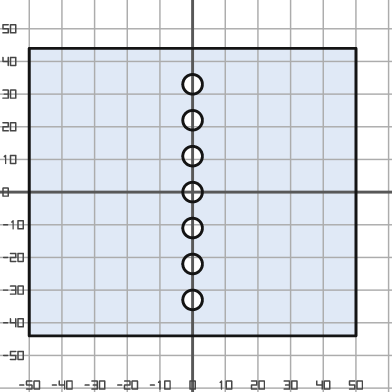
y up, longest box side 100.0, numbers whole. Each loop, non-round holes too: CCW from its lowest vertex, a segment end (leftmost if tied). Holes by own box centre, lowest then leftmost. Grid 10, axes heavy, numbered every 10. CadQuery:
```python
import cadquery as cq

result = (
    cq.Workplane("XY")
    .moveTo(-50.0, -44.0)
    .lineTo(50.0, -44.0)
    .lineTo(50.0, 44.0)
    .lineTo(-50.0, 44.0)
    .close()
    .moveTo(0.0, -33.0)
    .circle(3.0)
    .moveTo(0.0, -22.0)
    .circle(3.0)
    .moveTo(0.0, -11.0)
    .circle(3.0)
    .moveTo(0.0, 0.0)
    .circle(3.0)
    .moveTo(0.0, 11.0)
    .circle(3.0)
    .moveTo(0.0, 22.0)
    .circle(3.0)
    .moveTo(0.0, 33.0)
    .circle(3.0)
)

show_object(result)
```